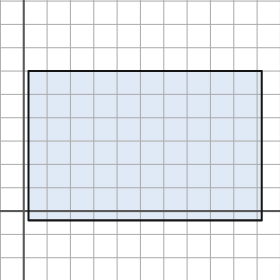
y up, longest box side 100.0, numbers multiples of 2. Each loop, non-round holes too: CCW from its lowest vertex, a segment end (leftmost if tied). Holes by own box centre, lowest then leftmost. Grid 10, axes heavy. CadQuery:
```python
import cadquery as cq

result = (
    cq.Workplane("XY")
    .moveTo(2.0, -4.0)
    .lineTo(102.0, -4.0)
    .lineTo(102.0, 60.0)
    .lineTo(2.0, 60.0)
    .close()
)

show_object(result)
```